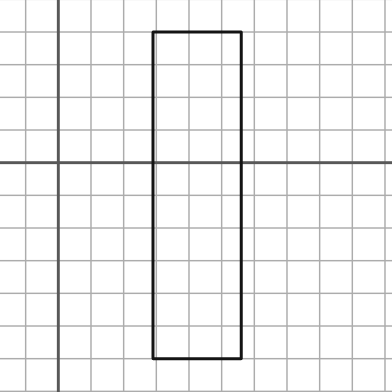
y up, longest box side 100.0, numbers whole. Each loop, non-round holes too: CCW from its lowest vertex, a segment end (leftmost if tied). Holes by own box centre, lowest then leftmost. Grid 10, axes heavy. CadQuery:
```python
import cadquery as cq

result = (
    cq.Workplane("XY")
    .moveTo(29.0, -60.0)
    .lineTo(56.0, -60.0)
    .lineTo(56.0, 40.0)
    .lineTo(29.0, 40.0)
    .close()
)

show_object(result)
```